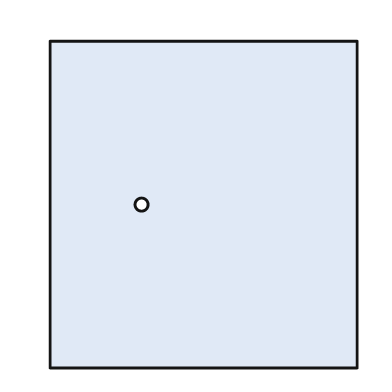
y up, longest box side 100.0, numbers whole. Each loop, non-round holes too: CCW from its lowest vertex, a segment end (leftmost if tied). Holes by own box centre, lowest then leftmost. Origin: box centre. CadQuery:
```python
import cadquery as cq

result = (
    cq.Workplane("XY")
    .moveTo(-47.0, -50.0)
    .lineTo(47.0, -50.0)
    .lineTo(47.0, 50.0)
    .lineTo(-47.0, 50.0)
    .close()
    .moveTo(-19.0, 0.0)
    .circle(2.0)
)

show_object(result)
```